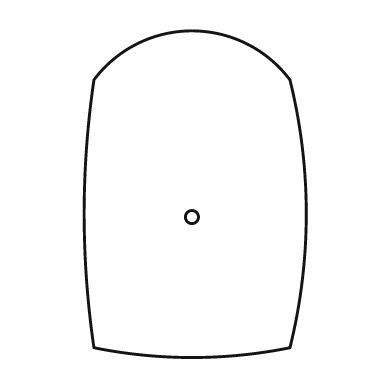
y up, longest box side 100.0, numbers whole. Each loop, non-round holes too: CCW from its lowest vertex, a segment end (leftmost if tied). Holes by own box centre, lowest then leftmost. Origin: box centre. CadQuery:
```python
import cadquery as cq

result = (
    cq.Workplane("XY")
    .moveTo(-31.0, -47.0)
    .threePointArc((-1.0, -50.0), (29.0, -47.0))
    .threePointArc((34.0, -6.0), (29.0, 35.0))
    .threePointArc((-1.0, 50.0), (-31.0, 35.0))
    .threePointArc((-34.0, -6.0), (-31.0, -47.0))
    .close()
    .moveTo(-1.0, -7.0)
    .circle(2.0)
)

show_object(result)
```